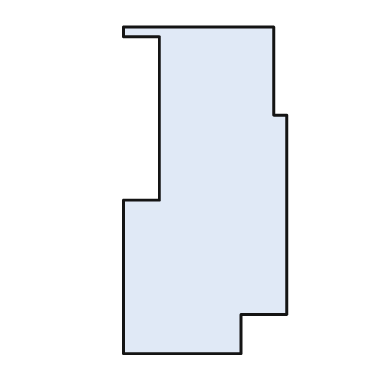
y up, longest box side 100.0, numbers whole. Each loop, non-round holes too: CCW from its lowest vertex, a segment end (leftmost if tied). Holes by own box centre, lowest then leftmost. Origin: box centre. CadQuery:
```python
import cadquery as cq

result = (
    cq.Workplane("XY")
    .moveTo(-25.0, -50.0)
    .lineTo(11.0, -50.0)
    .lineTo(11.0, -38.0)
    .lineTo(25.0, -38.0)
    .lineTo(25.0, 23.0)
    .lineTo(21.0, 23.0)
    .lineTo(21.0, 50.0)
    .lineTo(-25.0, 50.0)
    .lineTo(-25.0, 47.0)
    .lineTo(-14.0, 47.0)
    .lineTo(-14.0, -3.0)
    .lineTo(-25.0, -3.0)
    .close()
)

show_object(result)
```